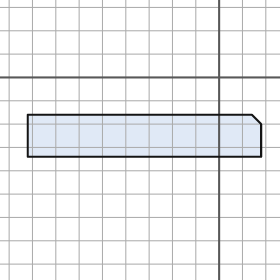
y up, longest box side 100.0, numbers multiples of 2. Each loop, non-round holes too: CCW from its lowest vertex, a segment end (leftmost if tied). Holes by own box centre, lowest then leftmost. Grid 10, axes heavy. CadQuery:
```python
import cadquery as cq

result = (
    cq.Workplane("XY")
    .moveTo(-82.0, -34.0)
    .lineTo(18.0, -34.0)
    .lineTo(18.0, -20.0)
    .lineTo(14.0, -16.0)
    .lineTo(-82.0, -16.0)
    .close()
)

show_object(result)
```